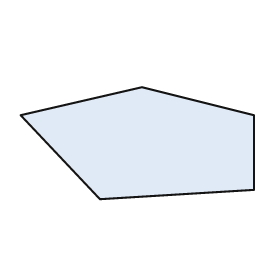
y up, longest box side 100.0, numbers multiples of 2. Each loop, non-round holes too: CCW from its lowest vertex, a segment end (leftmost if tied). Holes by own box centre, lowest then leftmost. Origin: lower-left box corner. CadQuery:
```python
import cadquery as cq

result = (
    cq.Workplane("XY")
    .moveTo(34.0, 0.0)
    .lineTo(100.0, 4.0)
    .lineTo(100.0, 36.0)
    .lineTo(52.0, 48.0)
    .lineTo(0.0, 36.0)
    .close()
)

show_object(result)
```